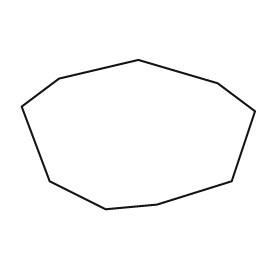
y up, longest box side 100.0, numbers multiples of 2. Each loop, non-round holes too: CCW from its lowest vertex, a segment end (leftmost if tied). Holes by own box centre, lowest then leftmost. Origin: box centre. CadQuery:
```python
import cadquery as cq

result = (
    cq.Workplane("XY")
    .moveTo(-14.0, -32.0)
    .lineTo(8.0, -30.0)
    .lineTo(40.0, -20.0)
    .lineTo(50.0, 10.0)
    .lineTo(34.0, 22.0)
    .lineTo(0.0, 32.0)
    .lineTo(-34.0, 24.0)
    .lineTo(-50.0, 12.0)
    .lineTo(-38.0, -20.0)
    .close()
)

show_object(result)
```